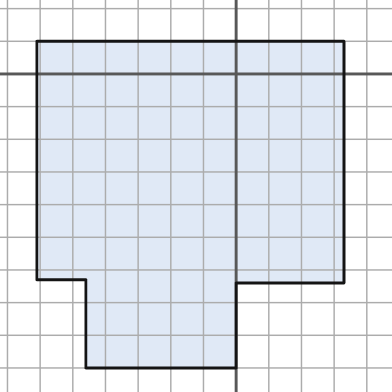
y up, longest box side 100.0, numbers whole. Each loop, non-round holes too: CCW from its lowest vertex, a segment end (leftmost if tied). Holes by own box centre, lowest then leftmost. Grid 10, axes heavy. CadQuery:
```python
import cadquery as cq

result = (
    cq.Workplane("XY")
    .moveTo(-46.0, -90.0)
    .lineTo(0.0, -90.0)
    .lineTo(0.0, -64.0)
    .lineTo(33.0, -64.0)
    .lineTo(33.0, 10.0)
    .lineTo(-61.0, 10.0)
    .lineTo(-61.0, -63.0)
    .lineTo(-46.0, -63.0)
    .close()
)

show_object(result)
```